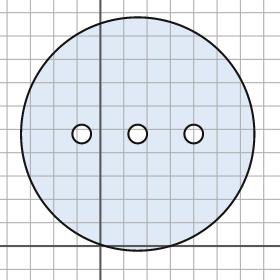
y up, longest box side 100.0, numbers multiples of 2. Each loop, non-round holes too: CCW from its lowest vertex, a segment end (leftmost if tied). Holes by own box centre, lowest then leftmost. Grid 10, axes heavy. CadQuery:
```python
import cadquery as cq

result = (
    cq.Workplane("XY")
    .moveTo(16.0, 48.0)
    .circle(50.0)
    .moveTo(-8.0, 48.0)
    .circle(4.0)
    .moveTo(16.0, 48.0)
    .circle(4.0)
    .moveTo(40.0, 48.0)
    .circle(4.0)
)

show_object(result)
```